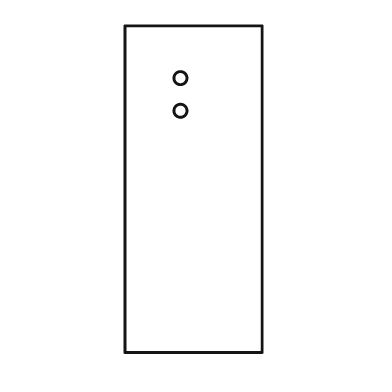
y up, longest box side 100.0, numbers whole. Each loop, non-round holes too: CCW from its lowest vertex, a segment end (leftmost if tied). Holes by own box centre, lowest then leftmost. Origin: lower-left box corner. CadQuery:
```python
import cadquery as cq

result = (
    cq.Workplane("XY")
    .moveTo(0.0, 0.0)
    .lineTo(42.0, 0.0)
    .lineTo(42.0, 100.0)
    .lineTo(0.0, 100.0)
    .close()
    .moveTo(17.0, 74.0)
    .circle(2.0)
    .moveTo(17.0, 84.0)
    .circle(2.0)
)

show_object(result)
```